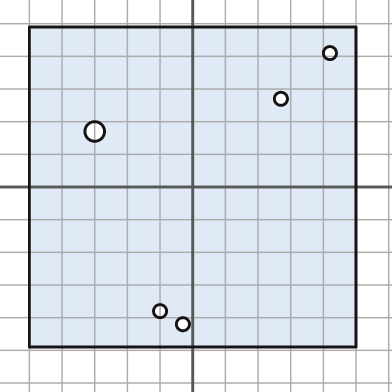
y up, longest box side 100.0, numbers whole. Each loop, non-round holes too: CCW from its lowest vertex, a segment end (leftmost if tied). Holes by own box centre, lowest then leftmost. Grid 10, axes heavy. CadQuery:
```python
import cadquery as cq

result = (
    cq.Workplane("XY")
    .moveTo(-50.0, -49.0)
    .lineTo(50.0, -49.0)
    .lineTo(50.0, 49.0)
    .lineTo(-50.0, 49.0)
    .close()
    .moveTo(-3.0, -42.0)
    .circle(2.0)
    .moveTo(-10.0, -38.0)
    .circle(2.0)
    .moveTo(-30.0, 17.0)
    .circle(3.0)
    .moveTo(27.0, 27.0)
    .circle(2.0)
    .moveTo(42.0, 41.0)
    .circle(2.0)
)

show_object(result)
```